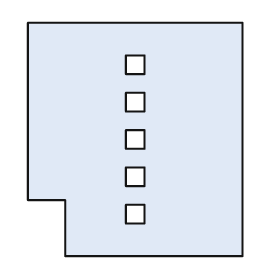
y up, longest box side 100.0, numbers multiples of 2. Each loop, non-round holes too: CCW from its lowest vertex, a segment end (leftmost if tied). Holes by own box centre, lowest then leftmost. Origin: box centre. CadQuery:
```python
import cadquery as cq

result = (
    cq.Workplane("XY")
    .moveTo(-30.0, -50.0)
    .lineTo(46.0, -50.0)
    .lineTo(46.0, 50.0)
    .lineTo(-46.0, 50.0)
    .lineTo(-46.0, -26.0)
    .lineTo(-30.0, -26.0)
    .close()
    .moveTo(-4.0, -36.0)
    .lineTo(4.0, -36.0)
    .lineTo(4.0, -28.0)
    .lineTo(-4.0, -28.0)
    .close()
    .moveTo(-4.0, -20.0)
    .lineTo(4.0, -20.0)
    .lineTo(4.0, -12.0)
    .lineTo(-4.0, -12.0)
    .close()
    .moveTo(-4.0, -4.0)
    .lineTo(4.0, -4.0)
    .lineTo(4.0, 4.0)
    .lineTo(-4.0, 4.0)
    .close()
    .moveTo(-4.0, 12.0)
    .lineTo(4.0, 12.0)
    .lineTo(4.0, 20.0)
    .lineTo(-4.0, 20.0)
    .close()
    .moveTo(-4.0, 28.0)
    .lineTo(4.0, 28.0)
    .lineTo(4.0, 36.0)
    .lineTo(-4.0, 36.0)
    .close()
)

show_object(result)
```